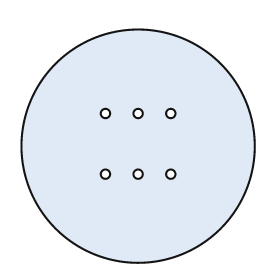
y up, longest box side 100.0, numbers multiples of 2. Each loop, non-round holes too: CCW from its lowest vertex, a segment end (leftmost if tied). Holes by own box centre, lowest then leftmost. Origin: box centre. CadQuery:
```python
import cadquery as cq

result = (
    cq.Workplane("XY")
    .moveTo(0.0, 0.0)
    .circle(50.0)
    .moveTo(-14.0, -12.0)
    .circle(2.0)
    .moveTo(0.0, -12.0)
    .circle(2.0)
    .moveTo(14.0, -12.0)
    .circle(2.0)
    .moveTo(-14.0, 14.0)
    .circle(2.0)
    .moveTo(0.0, 14.0)
    .circle(2.0)
    .moveTo(14.0, 14.0)
    .circle(2.0)
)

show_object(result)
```